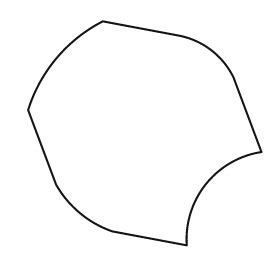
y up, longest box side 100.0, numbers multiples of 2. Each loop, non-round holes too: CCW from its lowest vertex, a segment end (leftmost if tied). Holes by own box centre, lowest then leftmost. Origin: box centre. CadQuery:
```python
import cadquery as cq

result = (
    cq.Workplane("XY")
    .moveTo(18.0, -48.0)
    .threePointArc((26.0, -22.0), (50.0, -8.0))
    .lineTo(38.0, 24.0)
    .threePointArc((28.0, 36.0), (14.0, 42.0))
    .lineTo(-18.0, 48.0)
    .threePointArc((-38.0, 32.0), (-50.0, 10.0))
    .lineTo(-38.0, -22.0)
    .threePointArc((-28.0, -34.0), (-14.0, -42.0))
    .close()
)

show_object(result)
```